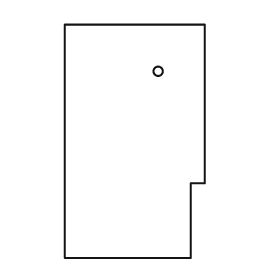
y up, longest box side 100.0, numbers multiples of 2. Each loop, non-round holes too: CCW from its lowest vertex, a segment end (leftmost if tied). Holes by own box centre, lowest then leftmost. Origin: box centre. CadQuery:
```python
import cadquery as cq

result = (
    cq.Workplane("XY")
    .moveTo(-30.0, -50.0)
    .lineTo(24.0, -50.0)
    .lineTo(24.0, -18.0)
    .lineTo(30.0, -18.0)
    .lineTo(30.0, 50.0)
    .lineTo(-30.0, 50.0)
    .close()
    .moveTo(10.0, 30.0)
    .circle(2.0)
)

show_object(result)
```